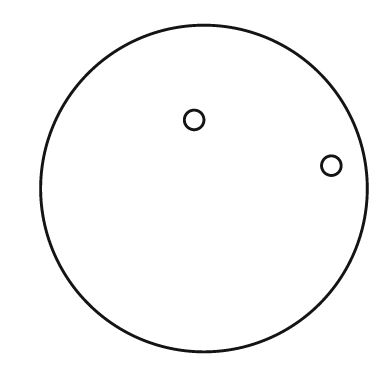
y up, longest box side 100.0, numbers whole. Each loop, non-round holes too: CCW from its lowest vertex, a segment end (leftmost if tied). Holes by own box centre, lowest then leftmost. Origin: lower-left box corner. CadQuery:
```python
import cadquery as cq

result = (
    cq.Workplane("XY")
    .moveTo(50.0, 50.0)
    .circle(50.0)
    .moveTo(89.0, 57.0)
    .circle(3.0)
    .moveTo(47.0, 71.0)
    .circle(3.0)
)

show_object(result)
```